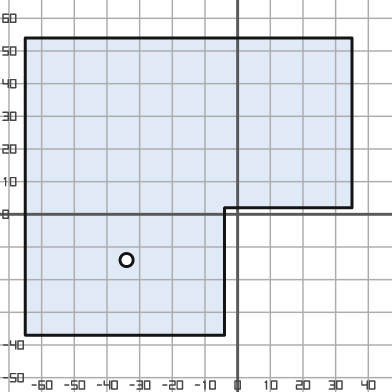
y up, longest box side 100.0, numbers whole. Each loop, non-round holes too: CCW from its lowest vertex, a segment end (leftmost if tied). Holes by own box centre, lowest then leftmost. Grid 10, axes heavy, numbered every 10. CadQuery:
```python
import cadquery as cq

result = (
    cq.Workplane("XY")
    .moveTo(-65.0, -37.0)
    .lineTo(-4.0, -37.0)
    .lineTo(-4.0, 2.0)
    .lineTo(35.0, 2.0)
    .lineTo(35.0, 54.0)
    .lineTo(-65.0, 54.0)
    .close()
    .moveTo(-34.0, -14.0)
    .circle(2.0)
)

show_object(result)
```